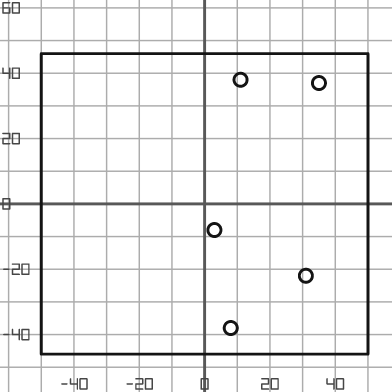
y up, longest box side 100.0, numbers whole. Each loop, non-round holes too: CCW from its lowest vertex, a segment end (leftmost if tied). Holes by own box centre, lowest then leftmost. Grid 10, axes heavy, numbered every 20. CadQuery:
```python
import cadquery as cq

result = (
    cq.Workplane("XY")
    .moveTo(-50.0, -46.0)
    .lineTo(50.0, -46.0)
    .lineTo(50.0, 46.0)
    .lineTo(-50.0, 46.0)
    .close()
    .moveTo(8.0, -38.0)
    .circle(2.0)
    .moveTo(31.0, -22.0)
    .circle(2.0)
    .moveTo(3.0, -8.0)
    .circle(2.0)
    .moveTo(35.0, 37.0)
    .circle(2.0)
    .moveTo(11.0, 38.0)
    .circle(2.0)
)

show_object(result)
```